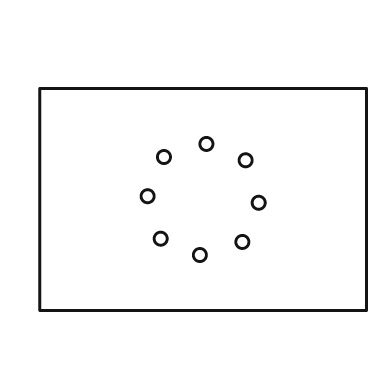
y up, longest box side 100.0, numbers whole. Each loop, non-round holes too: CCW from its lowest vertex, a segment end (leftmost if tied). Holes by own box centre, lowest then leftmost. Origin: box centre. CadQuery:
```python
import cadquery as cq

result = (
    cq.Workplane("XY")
    .moveTo(-50.0, -34.0)
    .lineTo(50.0, -34.0)
    .lineTo(50.0, 34.0)
    .lineTo(-50.0, 34.0)
    .close()
    .moveTo(-1.0, -17.0)
    .circle(2.0)
    .moveTo(12.0, -13.0)
    .circle(2.0)
    .moveTo(-13.0, -12.0)
    .circle(2.0)
    .moveTo(17.0, -1.0)
    .circle(2.0)
    .moveTo(-17.0, 1.0)
    .circle(2.0)
    .moveTo(13.0, 12.0)
    .circle(2.0)
    .moveTo(-12.0, 13.0)
    .circle(2.0)
    .moveTo(1.0, 17.0)
    .circle(2.0)
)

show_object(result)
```